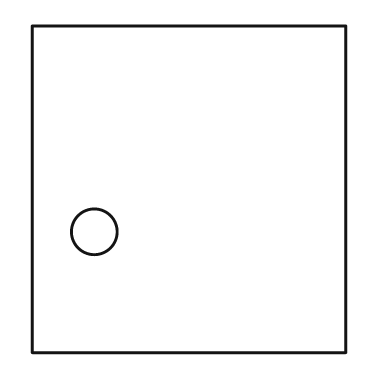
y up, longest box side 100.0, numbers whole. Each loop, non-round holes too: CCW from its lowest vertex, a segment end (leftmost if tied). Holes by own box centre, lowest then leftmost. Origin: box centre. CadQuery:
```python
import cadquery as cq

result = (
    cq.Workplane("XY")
    .moveTo(-48.0, -50.0)
    .lineTo(48.0, -50.0)
    .lineTo(48.0, 50.0)
    .lineTo(-48.0, 50.0)
    .close()
    .moveTo(-29.0, -13.0)
    .circle(7.0)
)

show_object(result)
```